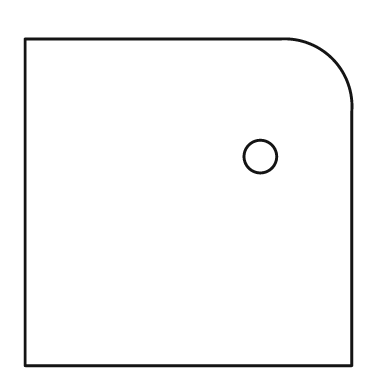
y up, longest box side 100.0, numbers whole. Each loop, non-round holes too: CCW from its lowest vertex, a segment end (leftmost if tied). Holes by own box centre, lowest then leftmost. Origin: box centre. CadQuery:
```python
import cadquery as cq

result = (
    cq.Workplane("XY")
    .moveTo(-50.0, -50.0)
    .lineTo(50.0, -50.0)
    .lineTo(50.0, 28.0)
    .threePointArc((44.0, 44.0), (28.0, 50.0))
    .lineTo(-50.0, 50.0)
    .close()
    .moveTo(22.0, 14.0)
    .circle(5.0)
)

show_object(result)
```